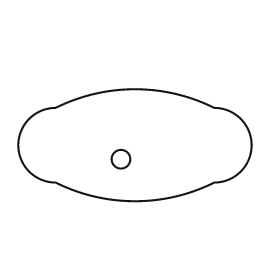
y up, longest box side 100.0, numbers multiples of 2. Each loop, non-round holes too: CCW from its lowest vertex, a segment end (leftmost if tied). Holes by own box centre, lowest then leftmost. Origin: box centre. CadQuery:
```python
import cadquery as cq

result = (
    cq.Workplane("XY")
    .moveTo(-34.0, -16.0)
    .threePointArc((0.0, -24.0), (34.0, -16.0))
    .threePointArc((50.0, 0.0), (34.0, 16.0))
    .threePointArc((0.0, 24.0), (-34.0, 16.0))
    .threePointArc((-50.0, 0.0), (-34.0, -16.0))
    .close()
    .moveTo(-6.0, -6.0)
    .circle(4.0)
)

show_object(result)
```